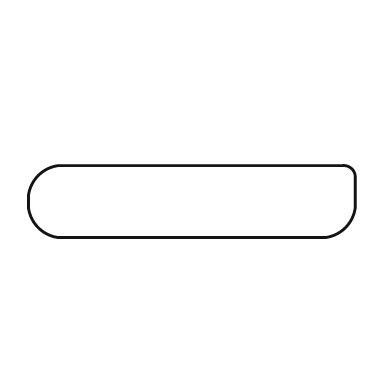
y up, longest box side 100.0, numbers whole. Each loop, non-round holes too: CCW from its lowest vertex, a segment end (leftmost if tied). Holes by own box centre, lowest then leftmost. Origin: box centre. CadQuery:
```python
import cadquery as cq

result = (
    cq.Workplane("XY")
    .moveTo(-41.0, -11.0)
    .lineTo(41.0, -11.0)
    .threePointArc((47.0, -8.0), (50.0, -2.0))
    .lineTo(50.0, 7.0)
    .threePointArc((49.0, 10.0), (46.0, 11.0))
    .lineTo(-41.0, 11.0)
    .threePointArc((-47.0, 8.0), (-50.0, 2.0))
    .lineTo(-50.0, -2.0)
    .threePointArc((-47.0, -8.0), (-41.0, -11.0))
    .close()
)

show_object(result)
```